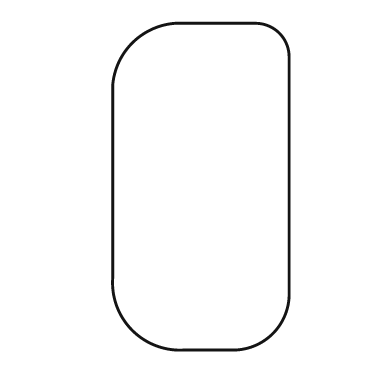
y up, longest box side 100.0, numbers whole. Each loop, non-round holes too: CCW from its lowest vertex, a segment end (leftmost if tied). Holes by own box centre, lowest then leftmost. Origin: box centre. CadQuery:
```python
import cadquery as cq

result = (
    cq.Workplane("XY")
    .moveTo(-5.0, -50.0)
    .lineTo(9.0, -50.0)
    .threePointArc((22.0, -45.0), (27.0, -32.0))
    .lineTo(27.0, 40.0)
    .threePointArc((24.0, 47.0), (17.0, 50.0))
    .lineTo(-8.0, 50.0)
    .threePointArc((-21.0, 44.0), (-27.0, 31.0))
    .lineTo(-27.0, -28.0)
    .threePointArc((-21.0, -44.0), (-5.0, -50.0))
    .close()
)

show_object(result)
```